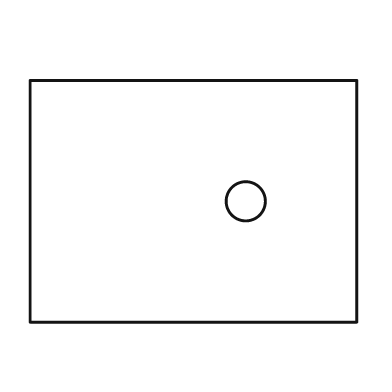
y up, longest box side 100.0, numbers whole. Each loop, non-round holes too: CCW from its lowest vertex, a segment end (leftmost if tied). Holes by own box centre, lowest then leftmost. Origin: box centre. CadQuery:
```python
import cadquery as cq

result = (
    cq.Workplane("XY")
    .moveTo(-50.0, -37.0)
    .lineTo(50.0, -37.0)
    .lineTo(50.0, 37.0)
    .lineTo(-50.0, 37.0)
    .close()
    .moveTo(16.0, 0.0)
    .circle(6.0)
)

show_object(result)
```